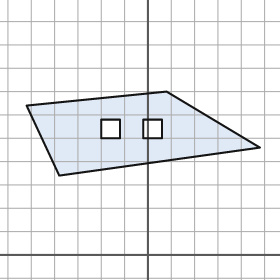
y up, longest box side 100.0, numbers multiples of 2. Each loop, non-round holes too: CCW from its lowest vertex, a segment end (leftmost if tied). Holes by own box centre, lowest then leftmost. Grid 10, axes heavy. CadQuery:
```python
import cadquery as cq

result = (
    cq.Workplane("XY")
    .moveTo(-38.0, 34.0)
    .lineTo(48.0, 46.0)
    .lineTo(8.0, 70.0)
    .lineTo(-52.0, 64.0)
    .close()
    .moveTo(-20.0, 50.0)
    .lineTo(-12.0, 50.0)
    .lineTo(-12.0, 58.0)
    .lineTo(-20.0, 58.0)
    .close()
    .moveTo(-2.0, 50.0)
    .lineTo(6.0, 50.0)
    .lineTo(6.0, 58.0)
    .lineTo(-2.0, 58.0)
    .close()
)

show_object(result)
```